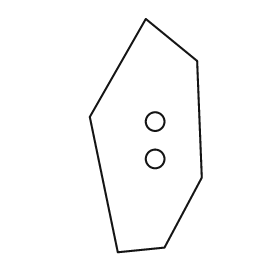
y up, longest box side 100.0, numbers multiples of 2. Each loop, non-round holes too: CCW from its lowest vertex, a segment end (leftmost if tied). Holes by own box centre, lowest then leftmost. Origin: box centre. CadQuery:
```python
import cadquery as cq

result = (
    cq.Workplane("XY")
    .moveTo(-12.0, -50.0)
    .lineTo(8.0, -48.0)
    .lineTo(24.0, -18.0)
    .lineTo(22.0, 32.0)
    .lineTo(0.0, 50.0)
    .lineTo(-24.0, 8.0)
    .close()
    .moveTo(4.0, -10.0)
    .circle(4.0)
    .moveTo(4.0, 6.0)
    .circle(4.0)
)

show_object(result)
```